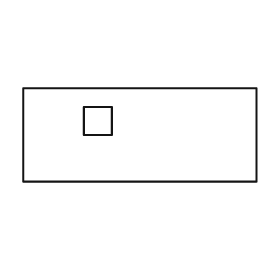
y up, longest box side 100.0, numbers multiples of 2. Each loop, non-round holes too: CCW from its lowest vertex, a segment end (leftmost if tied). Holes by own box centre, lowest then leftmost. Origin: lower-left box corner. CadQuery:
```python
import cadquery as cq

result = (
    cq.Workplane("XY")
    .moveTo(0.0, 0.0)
    .lineTo(100.0, 0.0)
    .lineTo(100.0, 40.0)
    .lineTo(0.0, 40.0)
    .close()
    .moveTo(26.0, 20.0)
    .lineTo(38.0, 20.0)
    .lineTo(38.0, 32.0)
    .lineTo(26.0, 32.0)
    .close()
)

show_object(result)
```